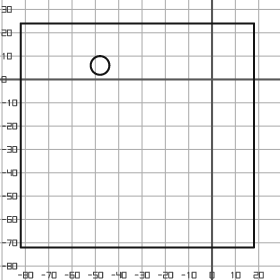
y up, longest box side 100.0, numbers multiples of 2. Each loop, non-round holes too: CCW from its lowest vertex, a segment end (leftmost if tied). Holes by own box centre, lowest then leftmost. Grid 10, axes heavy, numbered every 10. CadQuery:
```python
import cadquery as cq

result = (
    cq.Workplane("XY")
    .moveTo(-82.0, -72.0)
    .lineTo(18.0, -72.0)
    .lineTo(18.0, 24.0)
    .lineTo(-82.0, 24.0)
    .close()
    .moveTo(-48.0, 6.0)
    .circle(4.0)
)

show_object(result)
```